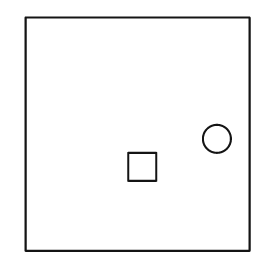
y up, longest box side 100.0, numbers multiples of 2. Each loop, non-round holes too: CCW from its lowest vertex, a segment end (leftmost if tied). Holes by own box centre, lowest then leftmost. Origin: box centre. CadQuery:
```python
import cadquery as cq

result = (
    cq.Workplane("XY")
    .moveTo(-48.0, -50.0)
    .lineTo(48.0, -50.0)
    .lineTo(48.0, 50.0)
    .lineTo(-48.0, 50.0)
    .close()
    .moveTo(-4.0, -20.0)
    .lineTo(8.0, -20.0)
    .lineTo(8.0, -8.0)
    .lineTo(-4.0, -8.0)
    .close()
    .moveTo(34.0, -2.0)
    .circle(6.0)
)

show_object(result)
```